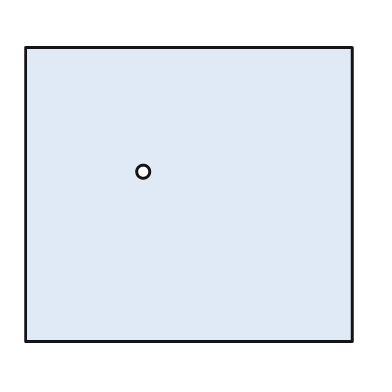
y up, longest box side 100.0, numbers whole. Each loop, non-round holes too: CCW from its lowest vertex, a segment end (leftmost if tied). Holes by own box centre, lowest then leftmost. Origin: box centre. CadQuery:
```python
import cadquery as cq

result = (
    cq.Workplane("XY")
    .moveTo(-50.0, -45.0)
    .lineTo(50.0, -45.0)
    .lineTo(50.0, 45.0)
    .lineTo(-50.0, 45.0)
    .close()
    .moveTo(-14.0, 7.0)
    .circle(2.0)
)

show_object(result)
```